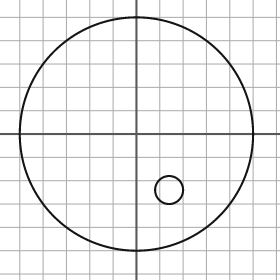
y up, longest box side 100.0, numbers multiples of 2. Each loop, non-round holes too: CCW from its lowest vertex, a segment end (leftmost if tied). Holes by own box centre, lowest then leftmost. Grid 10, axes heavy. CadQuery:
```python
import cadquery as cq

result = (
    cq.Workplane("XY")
    .moveTo(0.0, 0.0)
    .circle(50.0)
    .moveTo(14.0, -24.0)
    .circle(6.0)
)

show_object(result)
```